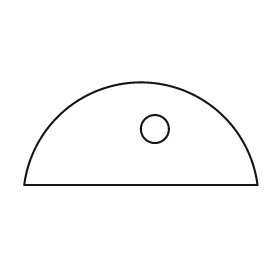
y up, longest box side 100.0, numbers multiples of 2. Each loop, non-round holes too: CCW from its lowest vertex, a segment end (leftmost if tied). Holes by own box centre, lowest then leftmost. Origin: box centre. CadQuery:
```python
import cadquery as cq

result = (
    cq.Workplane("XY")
    .moveTo(-50.0, -22.0)
    .lineTo(50.0, -22.0)
    .threePointArc((0.0, 22.0), (-50.0, -22.0))
    .close()
    .moveTo(6.0, 2.0)
    .circle(6.0)
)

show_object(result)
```